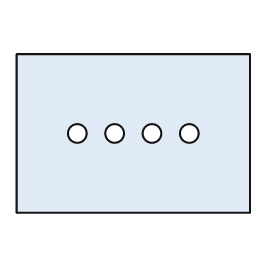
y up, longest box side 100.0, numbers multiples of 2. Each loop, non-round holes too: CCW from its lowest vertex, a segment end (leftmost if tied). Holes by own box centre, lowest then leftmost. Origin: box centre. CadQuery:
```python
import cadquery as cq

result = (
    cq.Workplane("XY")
    .moveTo(-50.0, -34.0)
    .lineTo(50.0, -34.0)
    .lineTo(50.0, 34.0)
    .lineTo(-50.0, 34.0)
    .close()
    .moveTo(-24.0, 0.0)
    .circle(4.0)
    .moveTo(-8.0, 0.0)
    .circle(4.0)
    .moveTo(8.0, 0.0)
    .circle(4.0)
    .moveTo(24.0, 0.0)
    .circle(4.0)
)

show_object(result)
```